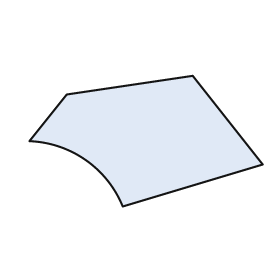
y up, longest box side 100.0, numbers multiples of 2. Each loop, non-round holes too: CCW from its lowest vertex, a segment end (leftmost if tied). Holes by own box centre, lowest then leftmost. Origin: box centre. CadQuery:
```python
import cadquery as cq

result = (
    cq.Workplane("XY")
    .moveTo(-10.0, -28.0)
    .lineTo(50.0, -10.0)
    .lineTo(20.0, 28.0)
    .lineTo(-34.0, 20.0)
    .lineTo(-50.0, 0.0)
    .threePointArc((-26.0, -8.0), (-10.0, -28.0))
    .close()
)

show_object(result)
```